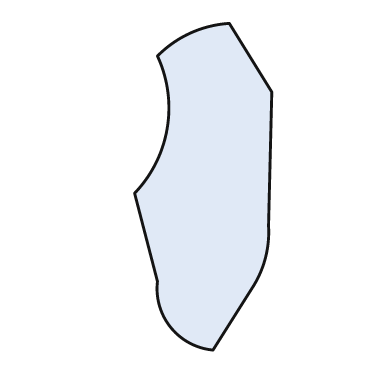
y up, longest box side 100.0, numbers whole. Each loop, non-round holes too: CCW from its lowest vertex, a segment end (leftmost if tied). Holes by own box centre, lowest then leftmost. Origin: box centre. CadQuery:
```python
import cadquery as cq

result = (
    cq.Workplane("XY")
    .moveTo(3.0, -50.0)
    .lineTo(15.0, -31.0)
    .threePointArc((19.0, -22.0), (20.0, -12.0))
    .lineTo(21.0, 29.0)
    .lineTo(8.0, 50.0)
    .threePointArc((-4.0, 47.0), (-14.0, 40.0))
    .threePointArc((-11.0, 18.0), (-21.0, -2.0))
    .lineTo(-14.0, -29.0)
    .threePointArc((-10.0, -43.0), (3.0, -50.0))
    .close()
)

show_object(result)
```